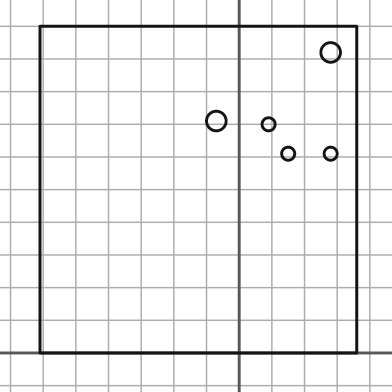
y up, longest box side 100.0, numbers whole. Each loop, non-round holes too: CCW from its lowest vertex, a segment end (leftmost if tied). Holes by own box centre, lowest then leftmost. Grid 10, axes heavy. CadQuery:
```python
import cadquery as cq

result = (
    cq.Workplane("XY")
    .moveTo(-61.0, 0.0)
    .lineTo(36.0, 0.0)
    .lineTo(36.0, 100.0)
    .lineTo(-61.0, 100.0)
    .close()
    .moveTo(15.0, 61.0)
    .circle(2.0)
    .moveTo(28.0, 61.0)
    .circle(2.0)
    .moveTo(9.0, 70.0)
    .circle(2.0)
    .moveTo(-7.0, 71.0)
    .circle(3.0)
    .moveTo(28.0, 92.0)
    .circle(3.0)
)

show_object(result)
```